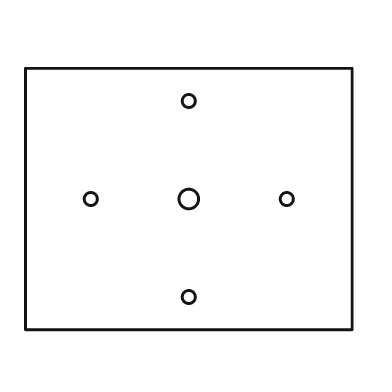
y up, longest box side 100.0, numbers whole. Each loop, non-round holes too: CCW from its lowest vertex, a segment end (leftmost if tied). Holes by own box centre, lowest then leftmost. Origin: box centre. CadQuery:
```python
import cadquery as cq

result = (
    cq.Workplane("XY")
    .moveTo(-50.0, -40.0)
    .lineTo(50.0, -40.0)
    .lineTo(50.0, 40.0)
    .lineTo(-50.0, 40.0)
    .close()
    .moveTo(0.0, -30.0)
    .circle(2.0)
    .moveTo(-30.0, 0.0)
    .circle(2.0)
    .moveTo(0.0, 0.0)
    .circle(3.0)
    .moveTo(30.0, 0.0)
    .circle(2.0)
    .moveTo(0.0, 30.0)
    .circle(2.0)
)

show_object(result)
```